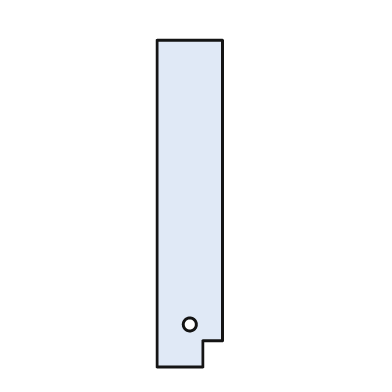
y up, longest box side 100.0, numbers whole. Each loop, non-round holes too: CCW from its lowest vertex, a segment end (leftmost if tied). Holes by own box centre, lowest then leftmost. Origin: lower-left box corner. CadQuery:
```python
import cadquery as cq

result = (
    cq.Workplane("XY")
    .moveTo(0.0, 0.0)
    .lineTo(14.0, 0.0)
    .lineTo(14.0, 8.0)
    .lineTo(20.0, 8.0)
    .lineTo(20.0, 100.0)
    .lineTo(0.0, 100.0)
    .close()
    .moveTo(10.0, 13.0)
    .circle(2.0)
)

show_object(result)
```